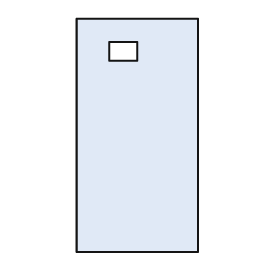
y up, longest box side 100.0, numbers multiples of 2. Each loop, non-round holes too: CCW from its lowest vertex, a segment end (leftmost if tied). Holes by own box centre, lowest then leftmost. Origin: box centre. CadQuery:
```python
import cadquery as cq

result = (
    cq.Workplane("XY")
    .moveTo(-26.0, -50.0)
    .lineTo(26.0, -50.0)
    .lineTo(26.0, 50.0)
    .lineTo(-26.0, 50.0)
    .close()
    .moveTo(-12.0, 32.0)
    .lineTo(0.0, 32.0)
    .lineTo(0.0, 40.0)
    .lineTo(-12.0, 40.0)
    .close()
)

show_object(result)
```